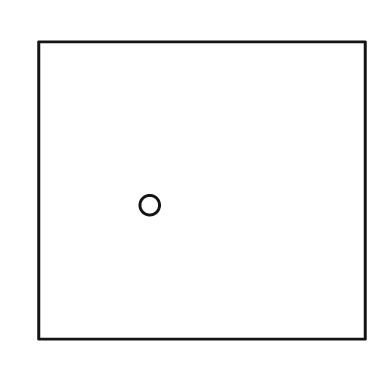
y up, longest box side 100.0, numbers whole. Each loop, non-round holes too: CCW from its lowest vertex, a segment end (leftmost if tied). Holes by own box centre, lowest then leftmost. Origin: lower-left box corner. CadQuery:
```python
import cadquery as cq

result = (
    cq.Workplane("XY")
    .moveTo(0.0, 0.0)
    .lineTo(100.0, 0.0)
    .lineTo(100.0, 91.0)
    .lineTo(0.0, 91.0)
    .close()
    .moveTo(34.0, 41.0)
    .circle(3.0)
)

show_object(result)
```